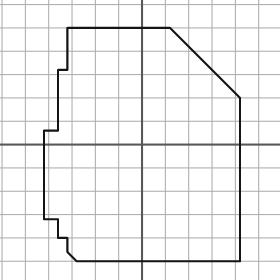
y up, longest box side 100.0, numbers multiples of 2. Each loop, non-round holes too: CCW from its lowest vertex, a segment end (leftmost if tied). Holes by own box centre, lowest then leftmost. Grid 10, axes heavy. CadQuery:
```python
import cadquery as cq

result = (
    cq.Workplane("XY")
    .moveTo(-28.0, -50.0)
    .lineTo(42.0, -50.0)
    .lineTo(42.0, 20.0)
    .lineTo(12.0, 50.0)
    .lineTo(-32.0, 50.0)
    .lineTo(-32.0, 32.0)
    .lineTo(-36.0, 32.0)
    .lineTo(-36.0, 6.0)
    .lineTo(-42.0, 6.0)
    .lineTo(-42.0, -32.0)
    .lineTo(-36.0, -32.0)
    .lineTo(-36.0, -40.0)
    .lineTo(-32.0, -40.0)
    .lineTo(-32.0, -46.0)
    .close()
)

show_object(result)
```